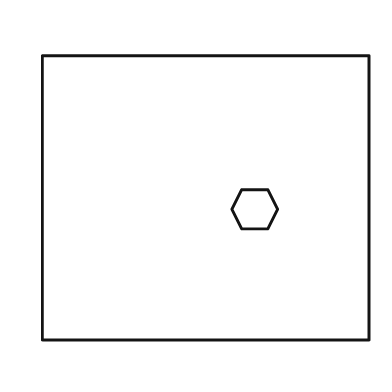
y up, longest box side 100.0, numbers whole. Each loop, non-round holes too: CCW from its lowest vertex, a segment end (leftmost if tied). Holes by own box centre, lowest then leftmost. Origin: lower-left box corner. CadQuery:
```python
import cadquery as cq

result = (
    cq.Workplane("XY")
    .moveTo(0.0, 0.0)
    .lineTo(100.0, 0.0)
    .lineTo(100.0, 87.0)
    .lineTo(0.0, 87.0)
    .close()
    .moveTo(61.0, 34.0)
    .lineTo(69.0, 34.0)
    .lineTo(72.0, 40.0)
    .lineTo(69.0, 46.0)
    .lineTo(61.0, 46.0)
    .lineTo(58.0, 40.0)
    .close()
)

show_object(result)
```